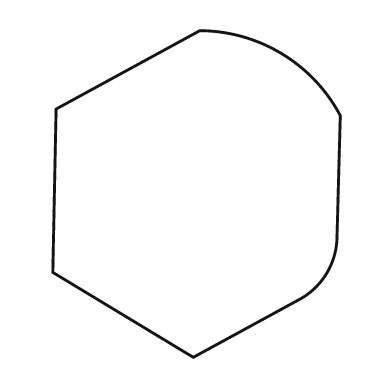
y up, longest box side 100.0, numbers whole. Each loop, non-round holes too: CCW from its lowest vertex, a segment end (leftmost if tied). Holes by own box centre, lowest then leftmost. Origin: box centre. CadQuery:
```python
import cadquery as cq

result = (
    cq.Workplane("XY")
    .moveTo(-1.0, -50.0)
    .lineTo(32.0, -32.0)
    .threePointArc((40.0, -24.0), (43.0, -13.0))
    .lineTo(44.0, 24.0)
    .threePointArc((26.0, 43.0), (1.0, 50.0))
    .lineTo(-43.0, 26.0)
    .lineTo(-44.0, -24.0)
    .close()
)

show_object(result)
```